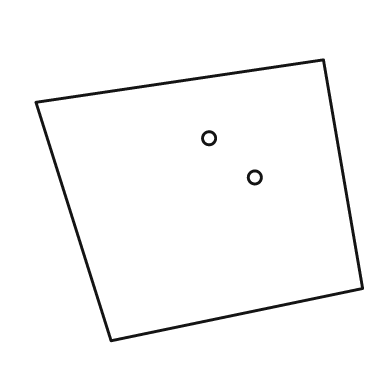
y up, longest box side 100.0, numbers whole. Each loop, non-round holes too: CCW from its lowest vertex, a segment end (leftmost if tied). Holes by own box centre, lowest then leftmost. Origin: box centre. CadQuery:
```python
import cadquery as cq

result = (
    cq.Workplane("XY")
    .moveTo(-27.0, -43.0)
    .lineTo(50.0, -27.0)
    .lineTo(38.0, 43.0)
    .lineTo(-50.0, 30.0)
    .close()
    .moveTo(17.0, 7.0)
    .circle(2.0)
    .moveTo(3.0, 19.0)
    .circle(2.0)
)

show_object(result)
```